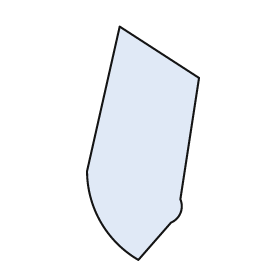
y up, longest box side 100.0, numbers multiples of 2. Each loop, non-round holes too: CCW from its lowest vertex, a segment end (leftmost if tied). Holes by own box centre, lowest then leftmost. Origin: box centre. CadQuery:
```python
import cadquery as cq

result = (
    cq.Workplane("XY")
    .moveTo(-2.0, -50.0)
    .lineTo(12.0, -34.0)
    .threePointArc((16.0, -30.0), (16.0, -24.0))
    .lineTo(24.0, 28.0)
    .lineTo(-10.0, 50.0)
    .lineTo(-24.0, -12.0)
    .threePointArc((-18.0, -34.0), (-2.0, -50.0))
    .close()
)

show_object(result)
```